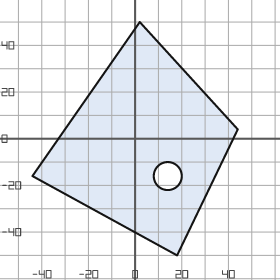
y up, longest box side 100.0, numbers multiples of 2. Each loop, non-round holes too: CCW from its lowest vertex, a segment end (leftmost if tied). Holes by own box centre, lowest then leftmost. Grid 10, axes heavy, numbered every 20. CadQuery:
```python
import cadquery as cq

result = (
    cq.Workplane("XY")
    .moveTo(18.0, -50.0)
    .lineTo(44.0, 4.0)
    .lineTo(2.0, 50.0)
    .lineTo(-44.0, -16.0)
    .close()
    .moveTo(14.0, -16.0)
    .circle(6.0)
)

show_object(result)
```